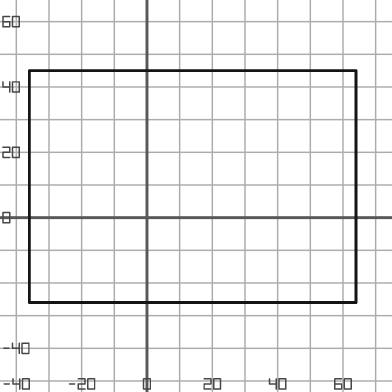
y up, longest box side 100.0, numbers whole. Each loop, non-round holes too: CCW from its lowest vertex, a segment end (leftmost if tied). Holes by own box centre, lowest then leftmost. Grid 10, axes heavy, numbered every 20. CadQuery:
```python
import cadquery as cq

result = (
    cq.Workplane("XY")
    .moveTo(-36.0, -26.0)
    .lineTo(64.0, -26.0)
    .lineTo(64.0, 45.0)
    .lineTo(-36.0, 45.0)
    .close()
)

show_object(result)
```